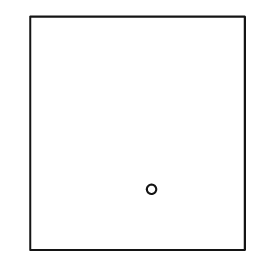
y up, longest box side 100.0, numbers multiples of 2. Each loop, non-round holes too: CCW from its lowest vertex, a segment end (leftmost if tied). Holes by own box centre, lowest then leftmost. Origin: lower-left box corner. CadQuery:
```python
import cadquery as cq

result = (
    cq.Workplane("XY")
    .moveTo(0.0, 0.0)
    .lineTo(92.0, 0.0)
    .lineTo(92.0, 100.0)
    .lineTo(0.0, 100.0)
    .close()
    .moveTo(52.0, 26.0)
    .circle(2.0)
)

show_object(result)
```